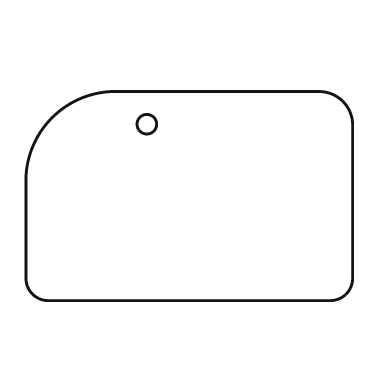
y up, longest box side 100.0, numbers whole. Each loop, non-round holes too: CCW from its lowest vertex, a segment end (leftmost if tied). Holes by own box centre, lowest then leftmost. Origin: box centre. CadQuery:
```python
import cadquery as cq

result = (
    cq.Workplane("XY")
    .moveTo(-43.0, -32.0)
    .lineTo(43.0, -32.0)
    .threePointArc((48.0, -30.0), (50.0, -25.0))
    .lineTo(50.0, 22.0)
    .threePointArc((47.0, 29.0), (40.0, 32.0))
    .lineTo(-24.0, 32.0)
    .threePointArc((-42.0, 24.0), (-50.0, 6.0))
    .lineTo(-50.0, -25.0)
    .threePointArc((-48.0, -30.0), (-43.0, -32.0))
    .close()
    .moveTo(-13.0, 22.0)
    .circle(3.0)
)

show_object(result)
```